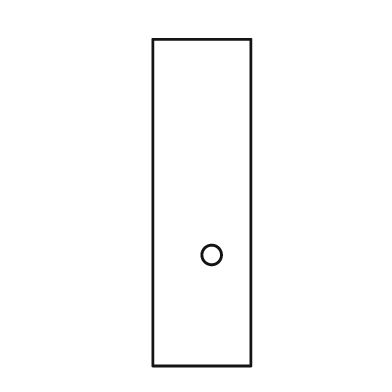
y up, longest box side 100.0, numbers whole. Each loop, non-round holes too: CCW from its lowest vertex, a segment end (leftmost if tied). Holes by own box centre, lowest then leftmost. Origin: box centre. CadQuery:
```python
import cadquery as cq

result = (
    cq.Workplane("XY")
    .moveTo(-15.0, -50.0)
    .lineTo(15.0, -50.0)
    .lineTo(15.0, 50.0)
    .lineTo(-15.0, 50.0)
    .close()
    .moveTo(3.0, -16.0)
    .circle(3.0)
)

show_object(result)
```